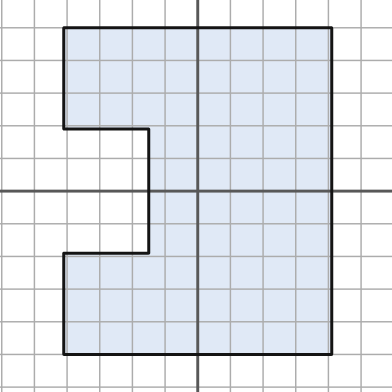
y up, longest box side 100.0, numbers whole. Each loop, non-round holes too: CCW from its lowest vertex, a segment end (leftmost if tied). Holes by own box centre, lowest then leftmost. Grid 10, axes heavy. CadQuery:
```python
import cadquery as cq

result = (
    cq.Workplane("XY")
    .moveTo(-41.0, -50.0)
    .lineTo(41.0, -50.0)
    .lineTo(41.0, 50.0)
    .lineTo(-41.0, 50.0)
    .lineTo(-41.0, 19.0)
    .lineTo(-15.0, 19.0)
    .lineTo(-15.0, -19.0)
    .lineTo(-41.0, -19.0)
    .close()
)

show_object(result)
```